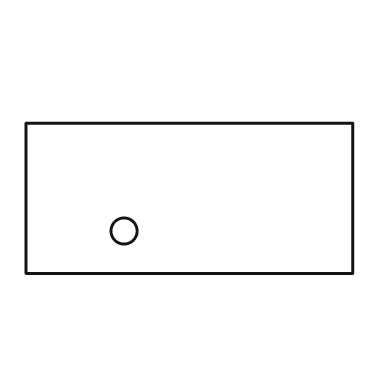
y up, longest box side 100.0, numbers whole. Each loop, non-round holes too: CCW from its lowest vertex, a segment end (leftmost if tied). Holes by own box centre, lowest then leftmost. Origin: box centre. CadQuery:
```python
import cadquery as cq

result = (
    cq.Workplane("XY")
    .moveTo(-50.0, -23.0)
    .lineTo(50.0, -23.0)
    .lineTo(50.0, 23.0)
    .lineTo(-50.0, 23.0)
    .close()
    .moveTo(-20.0, -10.0)
    .circle(4.0)
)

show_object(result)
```